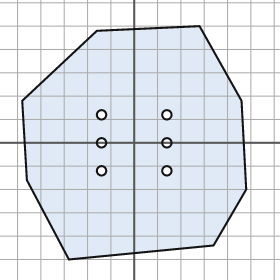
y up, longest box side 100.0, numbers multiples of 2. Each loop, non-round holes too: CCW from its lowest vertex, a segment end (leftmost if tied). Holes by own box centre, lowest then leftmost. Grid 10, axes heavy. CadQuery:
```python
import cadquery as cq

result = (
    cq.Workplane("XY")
    .moveTo(-28.0, -50.0)
    .lineTo(34.0, -44.0)
    .lineTo(48.0, -20.0)
    .lineTo(46.0, 18.0)
    .lineTo(28.0, 50.0)
    .lineTo(-16.0, 48.0)
    .lineTo(-48.0, 18.0)
    .lineTo(-46.0, -16.0)
    .close()
    .moveTo(-14.0, -12.0)
    .circle(2.0)
    .moveTo(14.0, -12.0)
    .circle(2.0)
    .moveTo(-14.0, 0.0)
    .circle(2.0)
    .moveTo(14.0, 0.0)
    .circle(2.0)
    .moveTo(-14.0, 12.0)
    .circle(2.0)
    .moveTo(14.0, 12.0)
    .circle(2.0)
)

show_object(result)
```